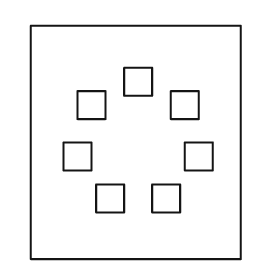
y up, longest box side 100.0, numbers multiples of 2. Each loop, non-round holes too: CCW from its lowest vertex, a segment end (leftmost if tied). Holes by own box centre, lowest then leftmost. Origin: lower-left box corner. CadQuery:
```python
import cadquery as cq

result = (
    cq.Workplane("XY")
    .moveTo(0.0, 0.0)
    .lineTo(90.0, 0.0)
    .lineTo(90.0, 100.0)
    .lineTo(0.0, 100.0)
    .close()
    .moveTo(28.0, 20.0)
    .lineTo(40.0, 20.0)
    .lineTo(40.0, 32.0)
    .lineTo(28.0, 32.0)
    .close()
    .moveTo(52.0, 20.0)
    .lineTo(64.0, 20.0)
    .lineTo(64.0, 32.0)
    .lineTo(52.0, 32.0)
    .close()
    .moveTo(14.0, 38.0)
    .lineTo(26.0, 38.0)
    .lineTo(26.0, 50.0)
    .lineTo(14.0, 50.0)
    .close()
    .moveTo(66.0, 38.0)
    .lineTo(78.0, 38.0)
    .lineTo(78.0, 50.0)
    .lineTo(66.0, 50.0)
    .close()
    .moveTo(20.0, 60.0)
    .lineTo(32.0, 60.0)
    .lineTo(32.0, 72.0)
    .lineTo(20.0, 72.0)
    .close()
    .moveTo(60.0, 60.0)
    .lineTo(72.0, 60.0)
    .lineTo(72.0, 72.0)
    .lineTo(60.0, 72.0)
    .close()
    .moveTo(40.0, 70.0)
    .lineTo(52.0, 70.0)
    .lineTo(52.0, 82.0)
    .lineTo(40.0, 82.0)
    .close()
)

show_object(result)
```